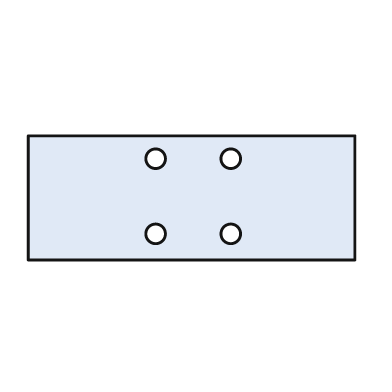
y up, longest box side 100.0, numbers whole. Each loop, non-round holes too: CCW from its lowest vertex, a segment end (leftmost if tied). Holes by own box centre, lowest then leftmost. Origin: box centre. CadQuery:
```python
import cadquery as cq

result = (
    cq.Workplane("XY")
    .moveTo(-50.0, -19.0)
    .lineTo(50.0, -19.0)
    .lineTo(50.0, 19.0)
    .lineTo(-50.0, 19.0)
    .close()
    .moveTo(-11.0, -11.0)
    .circle(3.0)
    .moveTo(12.0, -11.0)
    .circle(3.0)
    .moveTo(-11.0, 12.0)
    .circle(3.0)
    .moveTo(12.0, 12.0)
    .circle(3.0)
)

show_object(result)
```